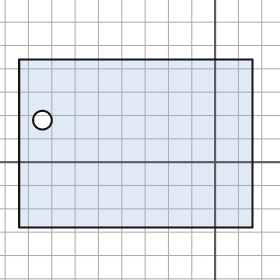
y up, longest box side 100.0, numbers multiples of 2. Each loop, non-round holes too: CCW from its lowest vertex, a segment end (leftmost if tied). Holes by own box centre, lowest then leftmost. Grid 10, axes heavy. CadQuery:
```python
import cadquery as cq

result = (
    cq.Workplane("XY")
    .moveTo(-84.0, -28.0)
    .lineTo(16.0, -28.0)
    .lineTo(16.0, 44.0)
    .lineTo(-84.0, 44.0)
    .close()
    .moveTo(-74.0, 18.0)
    .circle(4.0)
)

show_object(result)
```